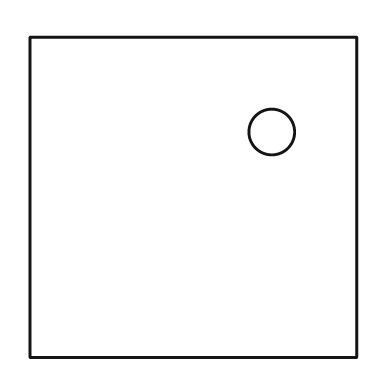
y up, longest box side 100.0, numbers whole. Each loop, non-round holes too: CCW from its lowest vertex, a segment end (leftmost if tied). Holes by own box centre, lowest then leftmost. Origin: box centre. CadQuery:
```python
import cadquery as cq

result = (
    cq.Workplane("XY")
    .moveTo(-50.0, -49.0)
    .lineTo(50.0, -49.0)
    .lineTo(50.0, 49.0)
    .lineTo(-50.0, 49.0)
    .close()
    .moveTo(24.0, 20.0)
    .circle(7.0)
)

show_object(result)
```